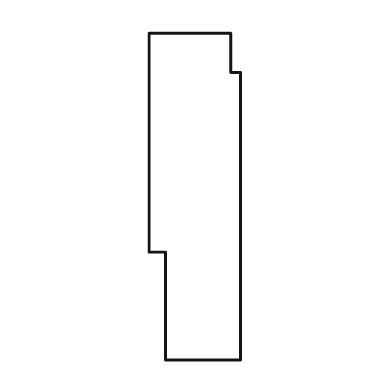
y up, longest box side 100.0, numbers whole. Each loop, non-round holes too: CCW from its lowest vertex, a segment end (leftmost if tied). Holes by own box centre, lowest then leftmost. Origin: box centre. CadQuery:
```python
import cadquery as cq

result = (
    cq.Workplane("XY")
    .moveTo(-9.0, -50.0)
    .lineTo(14.0, -50.0)
    .lineTo(14.0, 38.0)
    .lineTo(11.0, 38.0)
    .lineTo(11.0, 50.0)
    .lineTo(-14.0, 50.0)
    .lineTo(-14.0, -17.0)
    .lineTo(-9.0, -17.0)
    .close()
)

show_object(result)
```